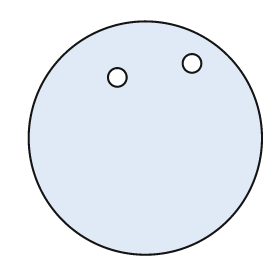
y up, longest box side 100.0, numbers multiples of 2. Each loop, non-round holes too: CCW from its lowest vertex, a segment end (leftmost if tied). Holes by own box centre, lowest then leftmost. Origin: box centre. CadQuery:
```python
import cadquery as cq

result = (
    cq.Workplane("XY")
    .moveTo(0.0, 0.0)
    .circle(50.0)
    .moveTo(-12.0, 26.0)
    .circle(4.0)
    .moveTo(20.0, 32.0)
    .circle(4.0)
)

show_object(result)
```